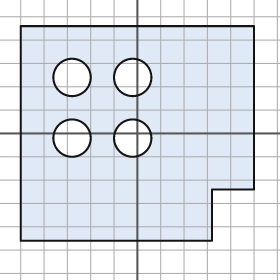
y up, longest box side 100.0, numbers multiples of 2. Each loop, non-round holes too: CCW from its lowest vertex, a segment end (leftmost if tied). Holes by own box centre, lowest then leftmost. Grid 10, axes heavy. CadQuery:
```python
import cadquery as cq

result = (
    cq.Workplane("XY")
    .moveTo(-50.0, -46.0)
    .lineTo(32.0, -46.0)
    .lineTo(32.0, -24.0)
    .lineTo(50.0, -24.0)
    .lineTo(50.0, 46.0)
    .lineTo(-50.0, 46.0)
    .close()
    .moveTo(-28.0, -2.0)
    .circle(8.0)
    .moveTo(-2.0, -2.0)
    .circle(8.0)
    .moveTo(-28.0, 24.0)
    .circle(8.0)
    .moveTo(-2.0, 24.0)
    .circle(8.0)
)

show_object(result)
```